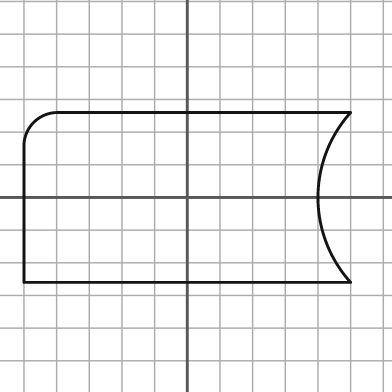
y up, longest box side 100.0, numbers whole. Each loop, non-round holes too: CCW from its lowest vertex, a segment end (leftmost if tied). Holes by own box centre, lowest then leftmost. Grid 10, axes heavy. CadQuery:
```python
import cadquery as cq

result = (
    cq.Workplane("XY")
    .moveTo(-50.0, -26.0)
    .lineTo(50.0, -26.0)
    .threePointArc((40.0, 0.0), (50.0, 26.0))
    .lineTo(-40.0, 26.0)
    .threePointArc((-47.0, 23.0), (-50.0, 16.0))
    .close()
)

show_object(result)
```